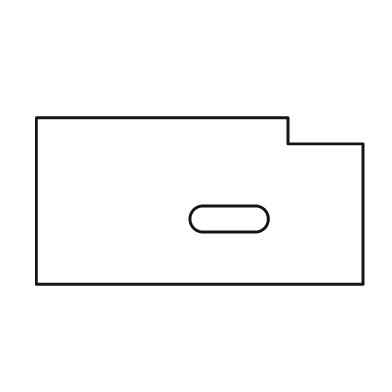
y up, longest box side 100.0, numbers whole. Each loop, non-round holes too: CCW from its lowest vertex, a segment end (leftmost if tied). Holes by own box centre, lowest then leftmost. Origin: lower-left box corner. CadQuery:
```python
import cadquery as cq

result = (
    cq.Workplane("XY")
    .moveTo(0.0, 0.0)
    .lineTo(100.0, 0.0)
    .lineTo(100.0, 43.0)
    .lineTo(77.0, 43.0)
    .lineTo(77.0, 51.0)
    .lineTo(0.0, 51.0)
    .close()
    .moveTo(51.0, 16.0)
    .lineTo(67.0, 16.0)
    .threePointArc((71.0, 20.0), (67.0, 24.0))
    .lineTo(51.0, 24.0)
    .threePointArc((47.0, 20.0), (51.0, 16.0))
    .close()
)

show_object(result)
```